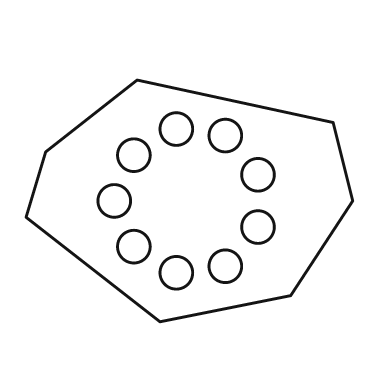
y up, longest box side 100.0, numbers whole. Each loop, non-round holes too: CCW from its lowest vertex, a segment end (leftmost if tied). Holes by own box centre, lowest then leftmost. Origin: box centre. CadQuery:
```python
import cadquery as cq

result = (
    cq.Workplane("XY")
    .moveTo(-9.0, -37.0)
    .lineTo(31.0, -29.0)
    .lineTo(50.0, 0.0)
    .lineTo(44.0, 24.0)
    .lineTo(-16.0, 37.0)
    .lineTo(-44.0, 15.0)
    .lineTo(-50.0, -5.0)
    .close()
    .moveTo(-4.0, -22.0)
    .circle(5.0)
    .moveTo(11.0, -20.0)
    .circle(5.0)
    .moveTo(-17.0, -14.0)
    .circle(5.0)
    .moveTo(21.0, -8.0)
    .circle(5.0)
    .moveTo(-23.0, 0.0)
    .circle(5.0)
    .moveTo(21.0, 8.0)
    .circle(5.0)
    .moveTo(-17.0, 14.0)
    .circle(5.0)
    .moveTo(11.0, 20.0)
    .circle(5.0)
    .moveTo(-4.0, 22.0)
    .circle(5.0)
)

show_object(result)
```